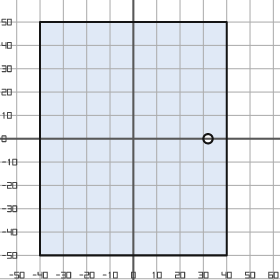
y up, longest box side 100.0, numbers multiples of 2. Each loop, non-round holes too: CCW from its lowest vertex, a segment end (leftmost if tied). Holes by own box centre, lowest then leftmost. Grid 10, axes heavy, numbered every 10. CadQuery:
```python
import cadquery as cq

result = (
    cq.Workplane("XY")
    .moveTo(-40.0, -50.0)
    .lineTo(40.0, -50.0)
    .lineTo(40.0, 50.0)
    .lineTo(-40.0, 50.0)
    .close()
    .moveTo(32.0, 0.0)
    .circle(2.0)
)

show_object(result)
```